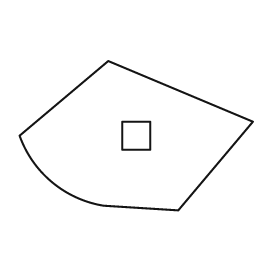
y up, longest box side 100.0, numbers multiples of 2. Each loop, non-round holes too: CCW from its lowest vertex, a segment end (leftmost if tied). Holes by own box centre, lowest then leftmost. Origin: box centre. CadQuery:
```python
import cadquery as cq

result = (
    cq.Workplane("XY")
    .moveTo(18.0, -32.0)
    .lineTo(50.0, 6.0)
    .lineTo(-12.0, 32.0)
    .lineTo(-50.0, 0.0)
    .threePointArc((-36.0, -20.0), (-14.0, -30.0))
    .close()
    .moveTo(-6.0, -6.0)
    .lineTo(6.0, -6.0)
    .lineTo(6.0, 6.0)
    .lineTo(-6.0, 6.0)
    .close()
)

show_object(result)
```